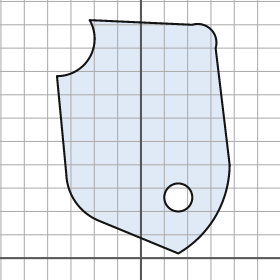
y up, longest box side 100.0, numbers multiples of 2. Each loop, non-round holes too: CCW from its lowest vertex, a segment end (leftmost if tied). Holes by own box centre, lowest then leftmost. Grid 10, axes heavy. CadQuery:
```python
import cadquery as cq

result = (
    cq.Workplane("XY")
    .moveTo(16.0, 2.0)
    .threePointArc((32.0, 18.0), (38.0, 40.0))
    .lineTo(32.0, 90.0)
    .threePointArc((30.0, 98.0), (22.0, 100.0))
    .lineTo(-22.0, 102.0)
    .threePointArc((-22.0, 86.0), (-36.0, 78.0))
    .lineTo(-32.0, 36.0)
    .threePointArc((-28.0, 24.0), (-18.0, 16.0))
    .close()
    .moveTo(16.0, 26.0)
    .circle(6.0)
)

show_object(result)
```